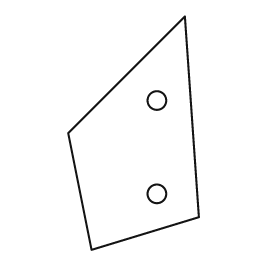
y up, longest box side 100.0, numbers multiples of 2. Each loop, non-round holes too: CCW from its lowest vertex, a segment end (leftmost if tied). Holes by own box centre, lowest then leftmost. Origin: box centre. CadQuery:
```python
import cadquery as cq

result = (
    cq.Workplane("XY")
    .moveTo(-18.0, -50.0)
    .lineTo(28.0, -36.0)
    .lineTo(22.0, 50.0)
    .lineTo(-28.0, 0.0)
    .close()
    .moveTo(10.0, -26.0)
    .circle(4.0)
    .moveTo(10.0, 14.0)
    .circle(4.0)
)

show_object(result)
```